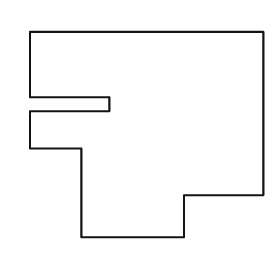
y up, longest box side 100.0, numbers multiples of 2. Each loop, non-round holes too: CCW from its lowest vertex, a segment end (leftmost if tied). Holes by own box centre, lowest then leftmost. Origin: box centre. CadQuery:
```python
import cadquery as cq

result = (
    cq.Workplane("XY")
    .moveTo(-28.0, -44.0)
    .lineTo(16.0, -44.0)
    .lineTo(16.0, -26.0)
    .lineTo(50.0, -26.0)
    .lineTo(50.0, 44.0)
    .lineTo(-50.0, 44.0)
    .lineTo(-50.0, 16.0)
    .lineTo(-16.0, 16.0)
    .lineTo(-16.0, 10.0)
    .lineTo(-50.0, 10.0)
    .lineTo(-50.0, -6.0)
    .lineTo(-28.0, -6.0)
    .close()
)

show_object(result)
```